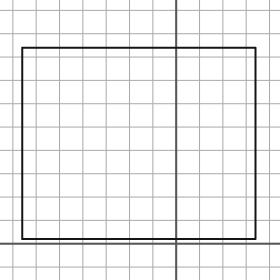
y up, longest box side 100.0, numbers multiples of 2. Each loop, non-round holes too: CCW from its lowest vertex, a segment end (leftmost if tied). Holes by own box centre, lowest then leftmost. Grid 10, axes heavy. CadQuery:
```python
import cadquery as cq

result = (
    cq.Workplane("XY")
    .moveTo(-66.0, 2.0)
    .lineTo(34.0, 2.0)
    .lineTo(34.0, 84.0)
    .lineTo(-66.0, 84.0)
    .close()
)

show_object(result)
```